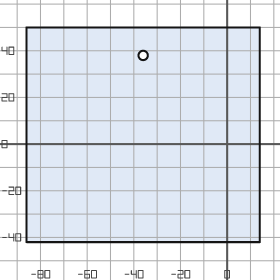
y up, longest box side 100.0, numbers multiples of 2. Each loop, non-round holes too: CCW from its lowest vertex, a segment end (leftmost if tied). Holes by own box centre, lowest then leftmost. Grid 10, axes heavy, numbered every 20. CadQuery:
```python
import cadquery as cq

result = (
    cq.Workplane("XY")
    .moveTo(-86.0, -42.0)
    .lineTo(14.0, -42.0)
    .lineTo(14.0, 50.0)
    .lineTo(-86.0, 50.0)
    .close()
    .moveTo(-36.0, 38.0)
    .circle(2.0)
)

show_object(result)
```